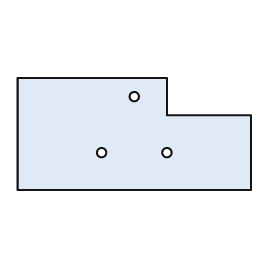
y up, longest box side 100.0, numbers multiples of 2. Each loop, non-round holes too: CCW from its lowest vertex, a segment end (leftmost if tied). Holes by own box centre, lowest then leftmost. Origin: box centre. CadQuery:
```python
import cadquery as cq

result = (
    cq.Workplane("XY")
    .moveTo(-50.0, -24.0)
    .lineTo(50.0, -24.0)
    .lineTo(50.0, 8.0)
    .lineTo(14.0, 8.0)
    .lineTo(14.0, 24.0)
    .lineTo(-50.0, 24.0)
    .close()
    .moveTo(-14.0, -8.0)
    .circle(2.0)
    .moveTo(14.0, -8.0)
    .circle(2.0)
    .moveTo(0.0, 16.0)
    .circle(2.0)
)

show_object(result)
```